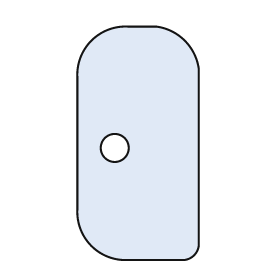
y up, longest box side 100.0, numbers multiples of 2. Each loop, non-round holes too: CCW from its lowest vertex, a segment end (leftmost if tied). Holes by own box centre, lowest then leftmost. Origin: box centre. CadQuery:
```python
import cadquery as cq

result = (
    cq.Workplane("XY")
    .moveTo(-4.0, -50.0)
    .lineTo(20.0, -50.0)
    .threePointArc((24.0, -48.0), (26.0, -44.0))
    .lineTo(26.0, 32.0)
    .threePointArc((20.0, 44.0), (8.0, 50.0))
    .lineTo(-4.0, 50.0)
    .threePointArc((-20.0, 44.0), (-26.0, 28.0))
    .lineTo(-26.0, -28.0)
    .threePointArc((-20.0, -44.0), (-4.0, -50.0))
    .close()
    .moveTo(-10.0, -2.0)
    .circle(6.0)
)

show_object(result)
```